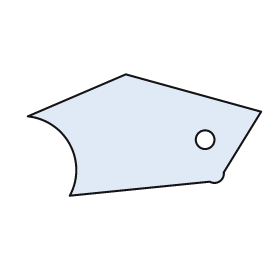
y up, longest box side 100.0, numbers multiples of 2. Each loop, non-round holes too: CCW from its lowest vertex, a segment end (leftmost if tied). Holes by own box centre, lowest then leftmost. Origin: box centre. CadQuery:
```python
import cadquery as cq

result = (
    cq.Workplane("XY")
    .moveTo(-32.0, -26.0)
    .lineTo(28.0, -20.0)
    .threePointArc((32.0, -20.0), (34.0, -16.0))
    .lineTo(50.0, 10.0)
    .lineTo(-8.0, 26.0)
    .lineTo(-50.0, 8.0)
    .threePointArc((-32.0, -4.0), (-32.0, -26.0))
    .close()
    .moveTo(26.0, -2.0)
    .circle(4.0)
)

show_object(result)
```